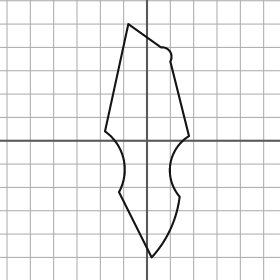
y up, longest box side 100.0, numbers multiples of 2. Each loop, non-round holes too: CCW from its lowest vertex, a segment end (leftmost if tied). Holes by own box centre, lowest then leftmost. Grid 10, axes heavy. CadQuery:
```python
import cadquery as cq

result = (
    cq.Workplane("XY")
    .moveTo(2.0, -50.0)
    .threePointArc((10.0, -38.0), (14.0, -24.0))
    .threePointArc((10.0, -10.0), (18.0, 2.0))
    .lineTo(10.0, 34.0)
    .threePointArc((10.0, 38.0), (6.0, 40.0))
    .lineTo(-8.0, 50.0)
    .lineTo(-18.0, 4.0)
    .threePointArc((-10.0, -8.0), (-12.0, -22.0))
    .close()
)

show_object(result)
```